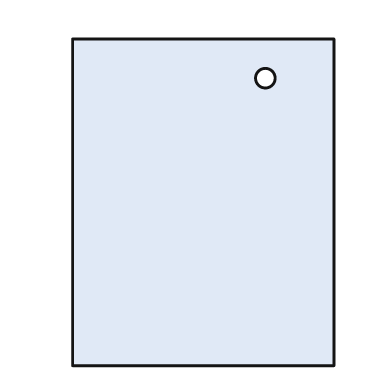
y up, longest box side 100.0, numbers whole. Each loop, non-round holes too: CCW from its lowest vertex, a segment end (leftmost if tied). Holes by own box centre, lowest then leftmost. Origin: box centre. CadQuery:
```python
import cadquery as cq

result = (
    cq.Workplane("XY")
    .moveTo(-40.0, -50.0)
    .lineTo(40.0, -50.0)
    .lineTo(40.0, 50.0)
    .lineTo(-40.0, 50.0)
    .close()
    .moveTo(19.0, 38.0)
    .circle(3.0)
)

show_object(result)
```